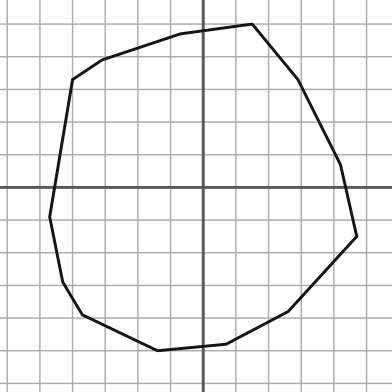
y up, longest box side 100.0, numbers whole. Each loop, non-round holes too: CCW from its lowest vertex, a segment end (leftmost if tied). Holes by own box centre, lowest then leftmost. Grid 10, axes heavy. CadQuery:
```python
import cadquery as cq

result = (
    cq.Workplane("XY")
    .moveTo(-14.0, -50.0)
    .lineTo(7.0, -48.0)
    .lineTo(26.0, -38.0)
    .lineTo(47.0, -15.0)
    .lineTo(42.0, 7.0)
    .lineTo(29.0, 33.0)
    .lineTo(15.0, 50.0)
    .lineTo(-7.0, 47.0)
    .lineTo(-31.0, 39.0)
    .lineTo(-40.0, 33.0)
    .lineTo(-47.0, -9.0)
    .lineTo(-43.0, -29.0)
    .lineTo(-37.0, -39.0)
    .close()
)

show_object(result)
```